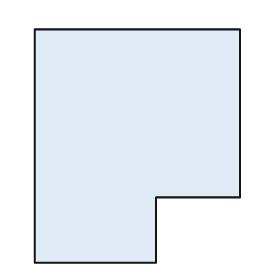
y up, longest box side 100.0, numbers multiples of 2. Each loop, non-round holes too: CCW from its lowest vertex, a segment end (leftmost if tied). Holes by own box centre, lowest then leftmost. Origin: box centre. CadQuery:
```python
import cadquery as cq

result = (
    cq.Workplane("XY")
    .moveTo(-44.0, -50.0)
    .lineTo(8.0, -50.0)
    .lineTo(8.0, -22.0)
    .lineTo(44.0, -22.0)
    .lineTo(44.0, 50.0)
    .lineTo(-44.0, 50.0)
    .close()
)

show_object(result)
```